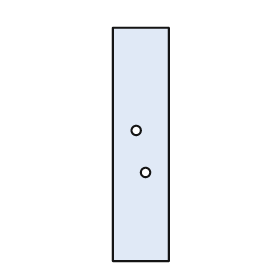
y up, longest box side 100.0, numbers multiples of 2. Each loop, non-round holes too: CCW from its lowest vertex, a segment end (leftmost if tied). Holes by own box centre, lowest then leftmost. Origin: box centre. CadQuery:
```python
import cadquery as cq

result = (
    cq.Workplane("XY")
    .moveTo(-12.0, -50.0)
    .lineTo(12.0, -50.0)
    .lineTo(12.0, 50.0)
    .lineTo(-12.0, 50.0)
    .close()
    .moveTo(2.0, -12.0)
    .circle(2.0)
    .moveTo(-2.0, 6.0)
    .circle(2.0)
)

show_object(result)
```